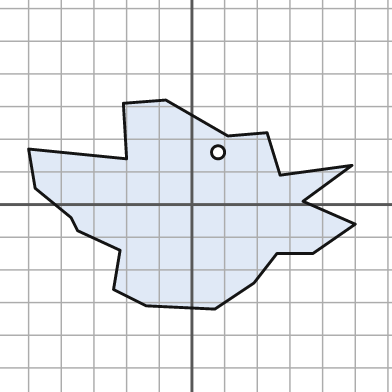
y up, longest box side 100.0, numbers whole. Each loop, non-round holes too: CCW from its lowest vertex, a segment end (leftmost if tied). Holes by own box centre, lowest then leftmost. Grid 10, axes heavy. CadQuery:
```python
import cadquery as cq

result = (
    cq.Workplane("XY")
    .moveTo(7.0, -32.0)
    .lineTo(19.0, -24.0)
    .lineTo(26.0, -15.0)
    .lineTo(37.0, -15.0)
    .lineTo(50.0, -6.0)
    .lineTo(34.0, 1.0)
    .lineTo(49.0, 12.0)
    .lineTo(27.0, 9.0)
    .lineTo(23.0, 22.0)
    .lineTo(11.0, 21.0)
    .lineTo(-8.0, 32.0)
    .lineTo(-21.0, 31.0)
    .lineTo(-20.0, 14.0)
    .lineTo(-50.0, 17.0)
    .lineTo(-48.0, 5.0)
    .lineTo(-37.0, -4.0)
    .lineTo(-35.0, -8.0)
    .lineTo(-22.0, -14.0)
    .lineTo(-24.0, -26.0)
    .lineTo(-14.0, -31.0)
    .close()
    .moveTo(8.0, 16.0)
    .circle(2.0)
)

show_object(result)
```